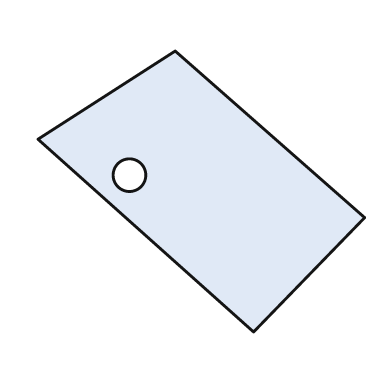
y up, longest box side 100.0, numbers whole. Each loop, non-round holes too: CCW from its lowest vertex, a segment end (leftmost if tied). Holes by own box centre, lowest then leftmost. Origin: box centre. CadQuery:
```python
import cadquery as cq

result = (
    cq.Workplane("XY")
    .moveTo(16.0, -43.0)
    .lineTo(50.0, -8.0)
    .lineTo(-8.0, 43.0)
    .lineTo(-50.0, 16.0)
    .close()
    .moveTo(-22.0, 5.0)
    .circle(5.0)
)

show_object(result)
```